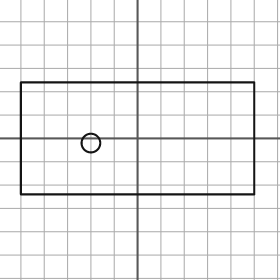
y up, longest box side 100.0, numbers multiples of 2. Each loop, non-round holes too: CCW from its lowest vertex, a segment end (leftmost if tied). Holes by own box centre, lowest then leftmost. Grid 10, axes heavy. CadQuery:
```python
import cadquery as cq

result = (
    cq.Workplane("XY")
    .moveTo(-50.0, -24.0)
    .lineTo(50.0, -24.0)
    .lineTo(50.0, 24.0)
    .lineTo(-50.0, 24.0)
    .close()
    .moveTo(-20.0, -2.0)
    .circle(4.0)
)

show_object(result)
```